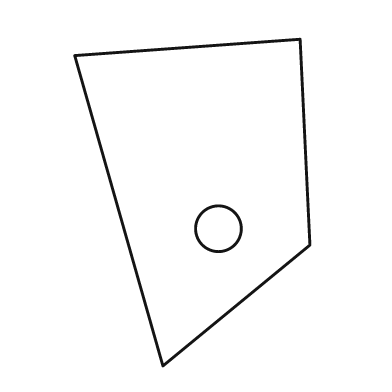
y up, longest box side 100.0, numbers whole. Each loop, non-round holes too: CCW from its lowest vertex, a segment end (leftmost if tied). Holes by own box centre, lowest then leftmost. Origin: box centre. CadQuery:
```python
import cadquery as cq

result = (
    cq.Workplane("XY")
    .moveTo(-9.0, -50.0)
    .lineTo(36.0, -13.0)
    .lineTo(33.0, 50.0)
    .lineTo(-36.0, 45.0)
    .close()
    .moveTo(8.0, -8.0)
    .circle(7.0)
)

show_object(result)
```